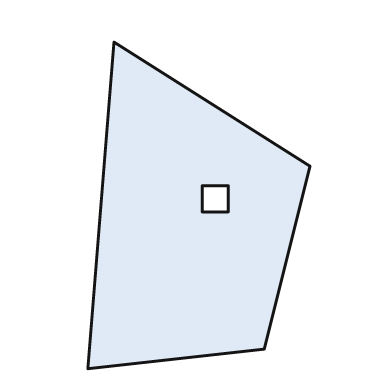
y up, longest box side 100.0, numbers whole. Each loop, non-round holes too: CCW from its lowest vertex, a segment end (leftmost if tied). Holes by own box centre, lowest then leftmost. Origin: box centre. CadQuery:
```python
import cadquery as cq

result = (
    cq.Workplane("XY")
    .moveTo(-34.0, -50.0)
    .lineTo(20.0, -44.0)
    .lineTo(34.0, 12.0)
    .lineTo(-26.0, 50.0)
    .close()
    .moveTo(1.0, -2.0)
    .lineTo(9.0, -2.0)
    .lineTo(9.0, 6.0)
    .lineTo(1.0, 6.0)
    .close()
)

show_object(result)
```